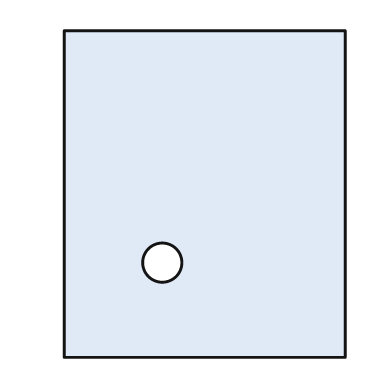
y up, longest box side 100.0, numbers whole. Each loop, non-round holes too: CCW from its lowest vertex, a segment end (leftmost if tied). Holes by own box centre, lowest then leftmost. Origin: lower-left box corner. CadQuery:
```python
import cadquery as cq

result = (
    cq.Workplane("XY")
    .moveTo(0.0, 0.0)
    .lineTo(86.0, 0.0)
    .lineTo(86.0, 100.0)
    .lineTo(0.0, 100.0)
    .close()
    .moveTo(30.0, 29.0)
    .circle(6.0)
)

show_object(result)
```